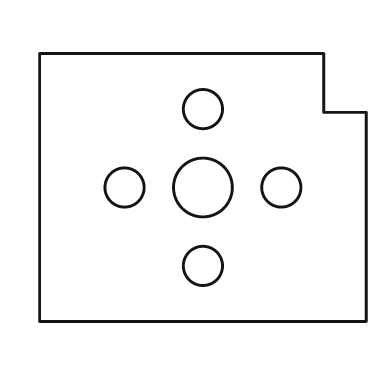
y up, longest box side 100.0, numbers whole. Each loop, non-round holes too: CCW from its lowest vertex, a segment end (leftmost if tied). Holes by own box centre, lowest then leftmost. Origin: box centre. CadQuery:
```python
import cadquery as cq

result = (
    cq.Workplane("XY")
    .moveTo(-50.0, -41.0)
    .lineTo(50.0, -41.0)
    .lineTo(50.0, 23.0)
    .lineTo(37.0, 23.0)
    .lineTo(37.0, 41.0)
    .lineTo(-50.0, 41.0)
    .close()
    .moveTo(0.0, -24.0)
    .circle(6.0)
    .moveTo(-24.0, 0.0)
    .circle(6.0)
    .moveTo(0.0, 0.0)
    .circle(9.0)
    .moveTo(24.0, 0.0)
    .circle(6.0)
    .moveTo(0.0, 24.0)
    .circle(6.0)
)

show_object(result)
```